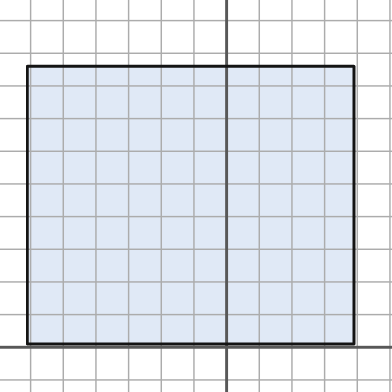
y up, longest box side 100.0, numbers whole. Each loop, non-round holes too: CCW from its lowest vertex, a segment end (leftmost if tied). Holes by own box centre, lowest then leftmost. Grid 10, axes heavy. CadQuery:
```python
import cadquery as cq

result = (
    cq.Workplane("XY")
    .moveTo(-61.0, 1.0)
    .lineTo(39.0, 1.0)
    .lineTo(39.0, 86.0)
    .lineTo(-61.0, 86.0)
    .close()
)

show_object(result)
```